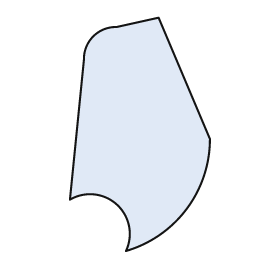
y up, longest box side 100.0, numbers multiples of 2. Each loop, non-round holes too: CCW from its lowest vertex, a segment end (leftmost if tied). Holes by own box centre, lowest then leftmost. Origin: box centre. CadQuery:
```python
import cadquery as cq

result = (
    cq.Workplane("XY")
    .moveTo(-6.0, -50.0)
    .threePointArc((20.0, -32.0), (30.0, -2.0))
    .lineTo(8.0, 50.0)
    .lineTo(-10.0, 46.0)
    .threePointArc((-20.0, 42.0), (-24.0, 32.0))
    .lineTo(-30.0, -28.0)
    .threePointArc((-10.0, -30.0), (-6.0, -50.0))
    .close()
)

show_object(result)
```